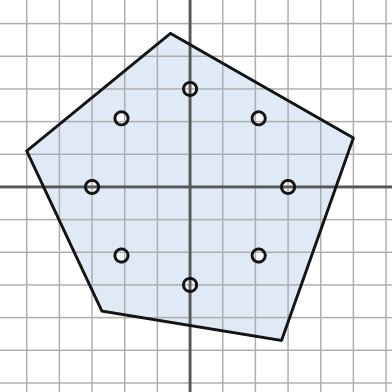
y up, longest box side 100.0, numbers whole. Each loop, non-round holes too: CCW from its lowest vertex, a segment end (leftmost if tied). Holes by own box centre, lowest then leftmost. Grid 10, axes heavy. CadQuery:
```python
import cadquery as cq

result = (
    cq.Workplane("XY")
    .moveTo(28.0, -47.0)
    .lineTo(50.0, 15.0)
    .lineTo(-6.0, 47.0)
    .lineTo(-50.0, 11.0)
    .lineTo(-27.0, -38.0)
    .close()
    .moveTo(0.0, -30.0)
    .circle(2.0)
    .moveTo(-21.0, -21.0)
    .circle(2.0)
    .moveTo(21.0, -21.0)
    .circle(2.0)
    .moveTo(-30.0, 0.0)
    .circle(2.0)
    .moveTo(30.0, 0.0)
    .circle(2.0)
    .moveTo(-21.0, 21.0)
    .circle(2.0)
    .moveTo(21.0, 21.0)
    .circle(2.0)
    .moveTo(0.0, 30.0)
    .circle(2.0)
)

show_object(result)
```